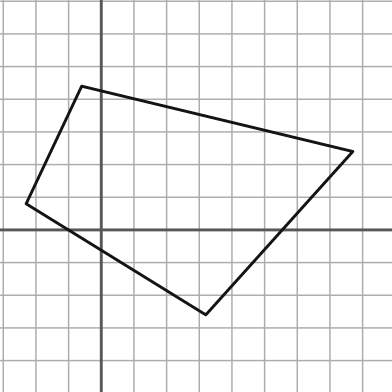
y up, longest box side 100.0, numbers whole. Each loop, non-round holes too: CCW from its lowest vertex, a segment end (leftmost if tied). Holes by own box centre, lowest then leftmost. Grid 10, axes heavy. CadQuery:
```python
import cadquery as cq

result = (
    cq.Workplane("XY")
    .moveTo(32.0, -26.0)
    .lineTo(77.0, 24.0)
    .lineTo(-6.0, 44.0)
    .lineTo(-23.0, 8.0)
    .close()
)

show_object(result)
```